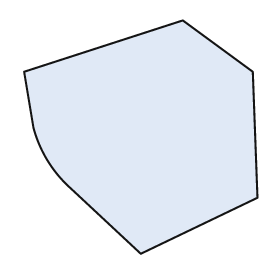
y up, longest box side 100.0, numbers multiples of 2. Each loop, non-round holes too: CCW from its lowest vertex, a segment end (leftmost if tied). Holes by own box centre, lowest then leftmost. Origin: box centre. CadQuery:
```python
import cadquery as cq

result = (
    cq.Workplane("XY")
    .moveTo(0.0, -50.0)
    .lineTo(50.0, -26.0)
    .lineTo(48.0, 28.0)
    .lineTo(18.0, 50.0)
    .lineTo(-50.0, 28.0)
    .lineTo(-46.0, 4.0)
    .threePointArc((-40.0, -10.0), (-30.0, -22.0))
    .close()
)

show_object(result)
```